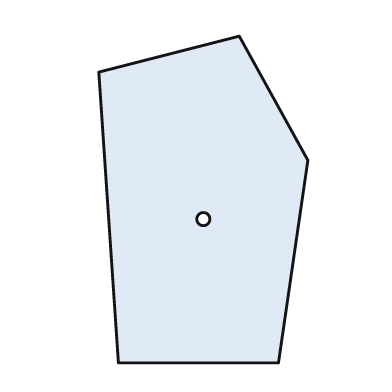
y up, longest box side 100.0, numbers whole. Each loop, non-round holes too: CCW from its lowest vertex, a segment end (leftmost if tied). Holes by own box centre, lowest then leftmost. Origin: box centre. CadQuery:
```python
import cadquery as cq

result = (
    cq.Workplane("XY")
    .moveTo(-26.0, -50.0)
    .lineTo(23.0, -50.0)
    .lineTo(32.0, 12.0)
    .lineTo(11.0, 50.0)
    .lineTo(-32.0, 39.0)
    .close()
    .moveTo(0.0, -6.0)
    .circle(2.0)
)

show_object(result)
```